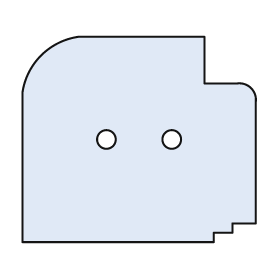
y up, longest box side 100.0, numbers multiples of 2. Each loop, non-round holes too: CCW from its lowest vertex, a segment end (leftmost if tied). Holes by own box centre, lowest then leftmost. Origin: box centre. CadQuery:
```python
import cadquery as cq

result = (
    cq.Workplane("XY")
    .moveTo(-50.0, -44.0)
    .lineTo(32.0, -44.0)
    .lineTo(32.0, -40.0)
    .lineTo(40.0, -40.0)
    .lineTo(40.0, -36.0)
    .lineTo(50.0, -36.0)
    .lineTo(50.0, 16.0)
    .threePointArc((48.0, 22.0), (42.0, 24.0))
    .lineTo(28.0, 24.0)
    .lineTo(28.0, 44.0)
    .lineTo(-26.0, 44.0)
    .threePointArc((-42.0, 36.0), (-50.0, 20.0))
    .close()
    .moveTo(-14.0, 0.0)
    .circle(4.0)
    .moveTo(14.0, 0.0)
    .circle(4.0)
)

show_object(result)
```